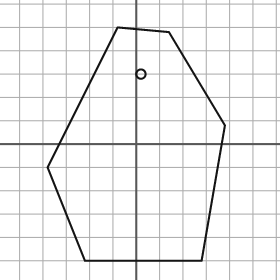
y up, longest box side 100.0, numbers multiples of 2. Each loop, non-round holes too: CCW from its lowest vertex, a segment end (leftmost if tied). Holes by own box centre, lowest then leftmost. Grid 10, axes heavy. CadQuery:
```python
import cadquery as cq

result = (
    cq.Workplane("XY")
    .moveTo(-22.0, -50.0)
    .lineTo(28.0, -50.0)
    .lineTo(38.0, 8.0)
    .lineTo(14.0, 48.0)
    .lineTo(-8.0, 50.0)
    .lineTo(-38.0, -10.0)
    .close()
    .moveTo(2.0, 30.0)
    .circle(2.0)
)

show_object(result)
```